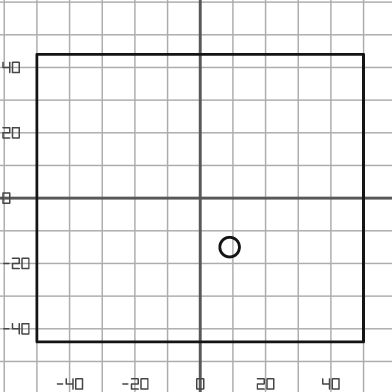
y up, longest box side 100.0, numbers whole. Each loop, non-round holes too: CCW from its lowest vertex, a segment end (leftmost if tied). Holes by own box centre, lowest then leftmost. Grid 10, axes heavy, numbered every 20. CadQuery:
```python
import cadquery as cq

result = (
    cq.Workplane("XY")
    .moveTo(-50.0, -44.0)
    .lineTo(50.0, -44.0)
    .lineTo(50.0, 44.0)
    .lineTo(-50.0, 44.0)
    .close()
    .moveTo(9.0, -15.0)
    .circle(3.0)
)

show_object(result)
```